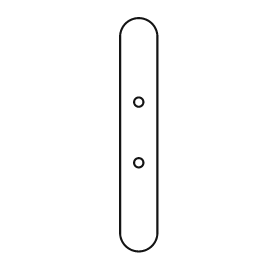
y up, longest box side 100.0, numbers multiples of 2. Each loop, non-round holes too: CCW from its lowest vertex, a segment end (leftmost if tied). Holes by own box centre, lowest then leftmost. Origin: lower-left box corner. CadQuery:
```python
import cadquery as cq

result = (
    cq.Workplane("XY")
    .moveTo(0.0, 8.0)
    .threePointArc((8.0, 0.0), (16.0, 8.0))
    .lineTo(16.0, 92.0)
    .threePointArc((8.0, 100.0), (0.0, 92.0))
    .close()
    .moveTo(8.0, 38.0)
    .circle(2.0)
    .moveTo(8.0, 64.0)
    .circle(2.0)
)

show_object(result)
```